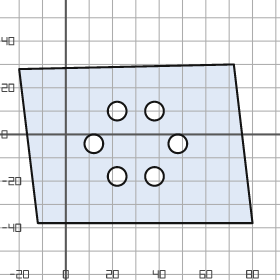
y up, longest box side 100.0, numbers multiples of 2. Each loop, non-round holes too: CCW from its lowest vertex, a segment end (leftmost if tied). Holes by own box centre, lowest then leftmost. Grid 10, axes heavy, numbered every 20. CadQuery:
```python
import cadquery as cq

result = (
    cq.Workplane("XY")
    .moveTo(-12.0, -38.0)
    .lineTo(80.0, -38.0)
    .lineTo(72.0, 30.0)
    .lineTo(-20.0, 28.0)
    .close()
    .moveTo(22.0, -18.0)
    .circle(4.0)
    .moveTo(38.0, -18.0)
    .circle(4.0)
    .moveTo(12.0, -4.0)
    .circle(4.0)
    .moveTo(48.0, -4.0)
    .circle(4.0)
    .moveTo(22.0, 10.0)
    .circle(4.0)
    .moveTo(38.0, 10.0)
    .circle(4.0)
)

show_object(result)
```